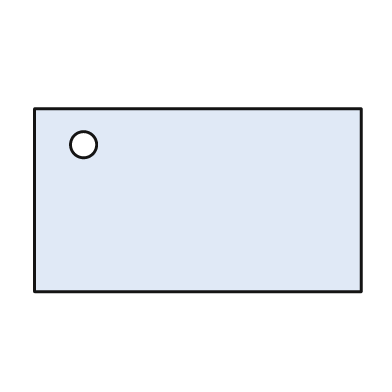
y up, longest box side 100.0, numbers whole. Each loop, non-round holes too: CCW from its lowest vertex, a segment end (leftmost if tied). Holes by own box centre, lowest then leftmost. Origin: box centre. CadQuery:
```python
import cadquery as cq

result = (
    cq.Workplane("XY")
    .moveTo(-50.0, -28.0)
    .lineTo(50.0, -28.0)
    .lineTo(50.0, 28.0)
    .lineTo(-50.0, 28.0)
    .close()
    .moveTo(-35.0, 17.0)
    .circle(4.0)
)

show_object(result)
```